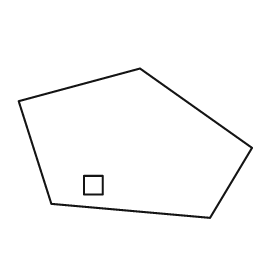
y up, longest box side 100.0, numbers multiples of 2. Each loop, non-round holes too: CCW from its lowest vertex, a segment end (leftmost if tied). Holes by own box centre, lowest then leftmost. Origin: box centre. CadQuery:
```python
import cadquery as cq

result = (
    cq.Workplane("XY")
    .moveTo(32.0, -32.0)
    .lineTo(50.0, -2.0)
    .lineTo(2.0, 32.0)
    .lineTo(-50.0, 18.0)
    .lineTo(-36.0, -26.0)
    .close()
    .moveTo(-22.0, -22.0)
    .lineTo(-14.0, -22.0)
    .lineTo(-14.0, -14.0)
    .lineTo(-22.0, -14.0)
    .close()
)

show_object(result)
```